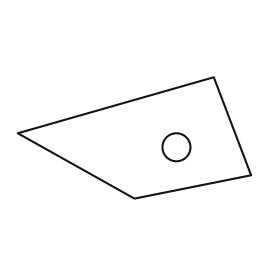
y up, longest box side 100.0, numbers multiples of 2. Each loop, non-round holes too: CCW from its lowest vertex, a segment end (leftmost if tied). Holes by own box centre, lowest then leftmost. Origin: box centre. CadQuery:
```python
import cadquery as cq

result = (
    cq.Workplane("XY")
    .moveTo(0.0, -26.0)
    .lineTo(50.0, -16.0)
    .lineTo(34.0, 26.0)
    .lineTo(-50.0, 2.0)
    .close()
    .moveTo(18.0, -4.0)
    .circle(6.0)
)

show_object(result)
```